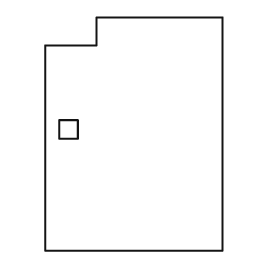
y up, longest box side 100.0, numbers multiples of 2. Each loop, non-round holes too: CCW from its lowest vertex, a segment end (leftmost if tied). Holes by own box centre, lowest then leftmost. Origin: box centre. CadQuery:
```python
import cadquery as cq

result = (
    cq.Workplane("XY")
    .moveTo(-38.0, -50.0)
    .lineTo(38.0, -50.0)
    .lineTo(38.0, 50.0)
    .lineTo(-16.0, 50.0)
    .lineTo(-16.0, 38.0)
    .lineTo(-38.0, 38.0)
    .close()
    .moveTo(-32.0, -2.0)
    .lineTo(-24.0, -2.0)
    .lineTo(-24.0, 6.0)
    .lineTo(-32.0, 6.0)
    .close()
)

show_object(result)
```